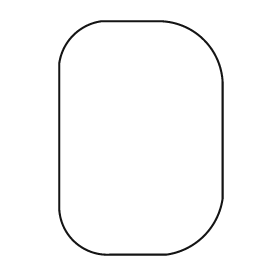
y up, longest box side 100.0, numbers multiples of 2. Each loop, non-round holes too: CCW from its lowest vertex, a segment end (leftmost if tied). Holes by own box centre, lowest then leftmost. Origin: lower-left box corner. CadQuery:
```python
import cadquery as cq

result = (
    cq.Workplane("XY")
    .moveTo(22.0, 0.0)
    .lineTo(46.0, 0.0)
    .threePointArc((62.0, 8.0), (70.0, 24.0))
    .lineTo(70.0, 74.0)
    .threePointArc((62.0, 92.0), (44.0, 100.0))
    .lineTo(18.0, 100.0)
    .threePointArc((6.0, 94.0), (0.0, 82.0))
    .lineTo(0.0, 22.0)
    .threePointArc((6.0, 6.0), (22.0, 0.0))
    .close()
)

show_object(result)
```